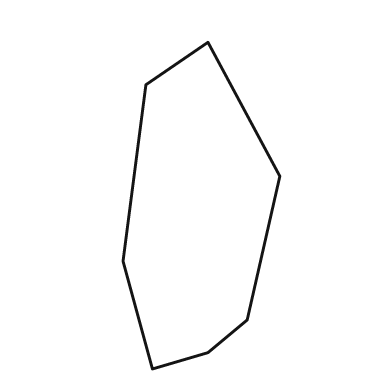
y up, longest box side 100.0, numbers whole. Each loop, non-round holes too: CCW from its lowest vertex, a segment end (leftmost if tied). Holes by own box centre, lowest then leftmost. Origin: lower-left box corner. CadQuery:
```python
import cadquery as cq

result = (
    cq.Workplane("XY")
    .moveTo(9.0, 0.0)
    .lineTo(26.0, 5.0)
    .lineTo(38.0, 15.0)
    .lineTo(48.0, 59.0)
    .lineTo(26.0, 100.0)
    .lineTo(7.0, 87.0)
    .lineTo(0.0, 33.0)
    .close()
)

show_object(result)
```